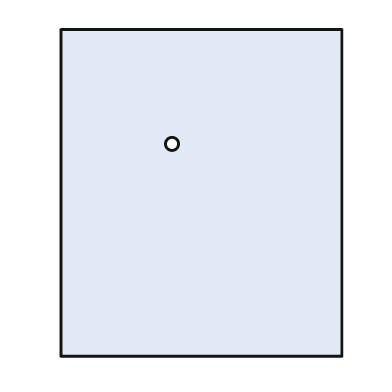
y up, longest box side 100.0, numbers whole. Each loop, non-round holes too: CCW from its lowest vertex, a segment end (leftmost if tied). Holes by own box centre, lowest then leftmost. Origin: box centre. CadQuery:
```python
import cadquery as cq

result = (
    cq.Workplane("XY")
    .moveTo(-43.0, -50.0)
    .lineTo(43.0, -50.0)
    .lineTo(43.0, 50.0)
    .lineTo(-43.0, 50.0)
    .close()
    .moveTo(-9.0, 15.0)
    .circle(2.0)
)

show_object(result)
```